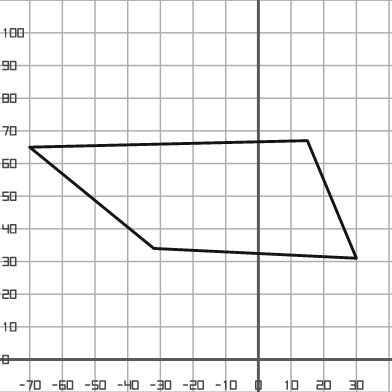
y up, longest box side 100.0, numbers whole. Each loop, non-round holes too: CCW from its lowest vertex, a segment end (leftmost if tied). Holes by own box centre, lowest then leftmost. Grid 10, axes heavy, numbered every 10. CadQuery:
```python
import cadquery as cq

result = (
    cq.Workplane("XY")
    .moveTo(30.0, 31.0)
    .lineTo(15.0, 67.0)
    .lineTo(-70.0, 65.0)
    .lineTo(-32.0, 34.0)
    .close()
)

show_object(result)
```